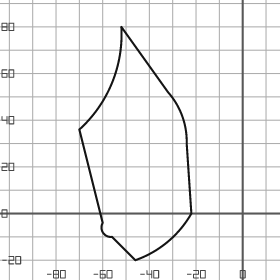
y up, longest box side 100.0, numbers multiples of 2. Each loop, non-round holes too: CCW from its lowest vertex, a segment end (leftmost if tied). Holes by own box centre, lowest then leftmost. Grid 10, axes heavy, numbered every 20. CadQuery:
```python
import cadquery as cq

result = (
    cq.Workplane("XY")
    .moveTo(-46.0, -20.0)
    .threePointArc((-32.0, -12.0), (-22.0, 0.0))
    .lineTo(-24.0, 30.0)
    .threePointArc((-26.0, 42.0), (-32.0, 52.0))
    .lineTo(-52.0, 80.0)
    .threePointArc((-56.0, 56.0), (-70.0, 36.0))
    .lineTo(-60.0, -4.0)
    .threePointArc((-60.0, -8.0), (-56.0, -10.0))
    .close()
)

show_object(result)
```